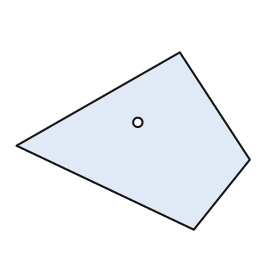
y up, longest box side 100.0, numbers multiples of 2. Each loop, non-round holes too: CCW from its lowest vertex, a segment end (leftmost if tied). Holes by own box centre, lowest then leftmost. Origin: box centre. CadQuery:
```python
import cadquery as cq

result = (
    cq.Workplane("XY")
    .moveTo(26.0, -38.0)
    .lineTo(50.0, -8.0)
    .lineTo(20.0, 38.0)
    .lineTo(-50.0, -2.0)
    .close()
    .moveTo(2.0, 8.0)
    .circle(2.0)
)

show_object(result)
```